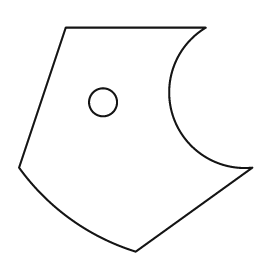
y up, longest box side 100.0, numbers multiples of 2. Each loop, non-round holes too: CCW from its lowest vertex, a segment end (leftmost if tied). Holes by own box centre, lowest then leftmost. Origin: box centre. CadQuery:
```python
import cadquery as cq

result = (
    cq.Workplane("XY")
    .moveTo(0.0, -48.0)
    .lineTo(50.0, -12.0)
    .threePointArc((16.0, 10.0), (30.0, 48.0))
    .lineTo(-30.0, 48.0)
    .lineTo(-50.0, -12.0)
    .threePointArc((-28.0, -34.0), (0.0, -48.0))
    .close()
    .moveTo(-14.0, 16.0)
    .circle(6.0)
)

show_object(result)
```